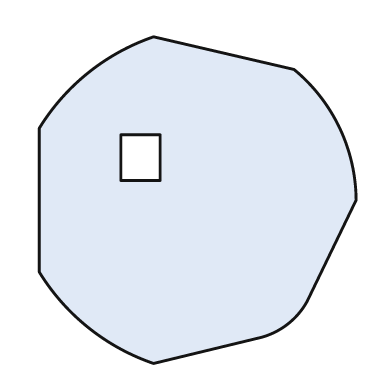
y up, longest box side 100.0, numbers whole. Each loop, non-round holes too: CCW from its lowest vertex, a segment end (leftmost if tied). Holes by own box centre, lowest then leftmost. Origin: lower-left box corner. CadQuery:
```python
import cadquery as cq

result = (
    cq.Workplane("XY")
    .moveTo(35.0, 0.0)
    .lineTo(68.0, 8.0)
    .threePointArc((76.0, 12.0), (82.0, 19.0))
    .lineTo(97.0, 50.0)
    .threePointArc((92.0, 72.0), (78.0, 90.0))
    .lineTo(35.0, 100.0)
    .threePointArc((15.0, 89.0), (0.0, 72.0))
    .lineTo(0.0, 28.0)
    .threePointArc((15.0, 11.0), (35.0, 0.0))
    .close()
    .moveTo(25.0, 56.0)
    .lineTo(37.0, 56.0)
    .lineTo(37.0, 70.0)
    .lineTo(25.0, 70.0)
    .close()
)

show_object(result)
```